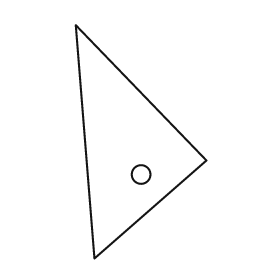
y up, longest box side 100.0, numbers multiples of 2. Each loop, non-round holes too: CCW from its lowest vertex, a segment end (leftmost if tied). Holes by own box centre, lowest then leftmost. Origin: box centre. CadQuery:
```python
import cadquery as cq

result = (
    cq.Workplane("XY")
    .moveTo(-20.0, -50.0)
    .lineTo(28.0, -8.0)
    .lineTo(-28.0, 50.0)
    .close()
    .moveTo(0.0, -14.0)
    .circle(4.0)
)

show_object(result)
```